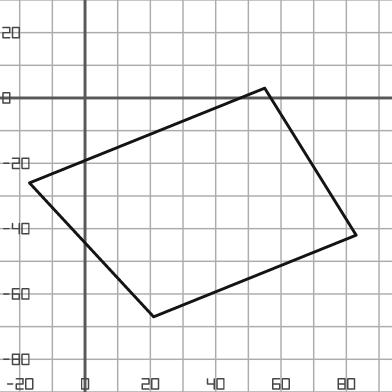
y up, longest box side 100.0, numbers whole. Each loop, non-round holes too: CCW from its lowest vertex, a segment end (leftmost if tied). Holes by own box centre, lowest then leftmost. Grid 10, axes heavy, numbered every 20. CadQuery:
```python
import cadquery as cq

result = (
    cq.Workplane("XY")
    .moveTo(21.0, -67.0)
    .lineTo(83.0, -42.0)
    .lineTo(55.0, 3.0)
    .lineTo(-17.0, -26.0)
    .close()
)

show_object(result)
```